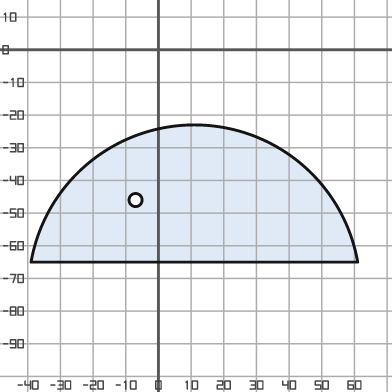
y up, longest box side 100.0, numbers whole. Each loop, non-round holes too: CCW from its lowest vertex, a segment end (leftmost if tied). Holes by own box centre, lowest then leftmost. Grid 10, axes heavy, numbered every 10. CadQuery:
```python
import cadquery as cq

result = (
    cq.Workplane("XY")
    .moveTo(-39.0, -65.0)
    .lineTo(61.0, -65.0)
    .threePointArc((11.0, -23.0), (-39.0, -65.0))
    .close()
    .moveTo(-7.0, -46.0)
    .circle(2.0)
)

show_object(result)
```